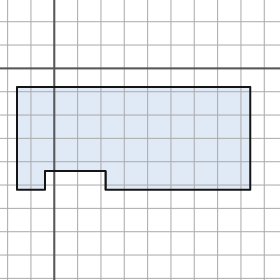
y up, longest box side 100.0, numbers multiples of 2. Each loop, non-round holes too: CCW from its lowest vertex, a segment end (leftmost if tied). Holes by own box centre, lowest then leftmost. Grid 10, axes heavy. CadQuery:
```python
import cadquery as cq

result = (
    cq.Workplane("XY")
    .moveTo(-16.0, -52.0)
    .lineTo(-4.0, -52.0)
    .lineTo(-4.0, -44.0)
    .lineTo(22.0, -44.0)
    .lineTo(22.0, -52.0)
    .lineTo(84.0, -52.0)
    .lineTo(84.0, -8.0)
    .lineTo(-16.0, -8.0)
    .close()
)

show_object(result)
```